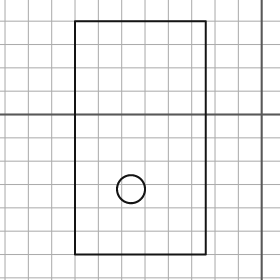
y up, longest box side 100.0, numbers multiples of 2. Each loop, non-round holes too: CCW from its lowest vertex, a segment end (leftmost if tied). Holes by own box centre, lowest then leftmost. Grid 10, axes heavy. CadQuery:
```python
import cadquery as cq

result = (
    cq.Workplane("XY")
    .moveTo(-80.0, -60.0)
    .lineTo(-24.0, -60.0)
    .lineTo(-24.0, 40.0)
    .lineTo(-80.0, 40.0)
    .close()
    .moveTo(-56.0, -32.0)
    .circle(6.0)
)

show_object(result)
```